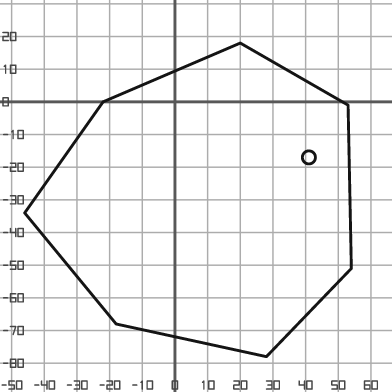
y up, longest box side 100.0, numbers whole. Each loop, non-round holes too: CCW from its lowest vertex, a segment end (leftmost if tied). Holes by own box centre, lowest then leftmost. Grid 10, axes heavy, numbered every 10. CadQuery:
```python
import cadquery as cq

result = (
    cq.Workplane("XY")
    .moveTo(28.0, -78.0)
    .lineTo(54.0, -51.0)
    .lineTo(53.0, -1.0)
    .lineTo(20.0, 18.0)
    .lineTo(-22.0, 0.0)
    .lineTo(-46.0, -34.0)
    .lineTo(-18.0, -68.0)
    .close()
    .moveTo(41.0, -17.0)
    .circle(2.0)
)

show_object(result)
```